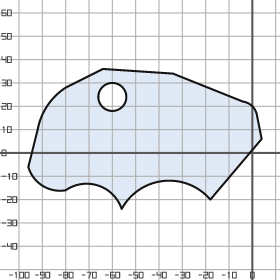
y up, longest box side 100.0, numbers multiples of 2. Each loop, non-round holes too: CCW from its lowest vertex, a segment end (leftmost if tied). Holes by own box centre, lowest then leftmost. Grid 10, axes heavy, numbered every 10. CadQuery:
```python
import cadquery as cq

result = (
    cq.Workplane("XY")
    .moveTo(-56.0, -24.0)
    .threePointArc((-38.0, -12.0), (-18.0, -20.0))
    .lineTo(4.0, 6.0)
    .lineTo(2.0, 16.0)
    .threePointArc((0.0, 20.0), (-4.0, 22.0))
    .lineTo(-34.0, 34.0)
    .lineTo(-64.0, 36.0)
    .lineTo(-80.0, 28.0)
    .threePointArc((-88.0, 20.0), (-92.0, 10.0))
    .lineTo(-96.0, -6.0)
    .threePointArc((-90.0, -14.0), (-80.0, -16.0))
    .threePointArc((-66.0, -14.0), (-56.0, -24.0))
    .close()
    .moveTo(-60.0, 24.0)
    .circle(6.0)
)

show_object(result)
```